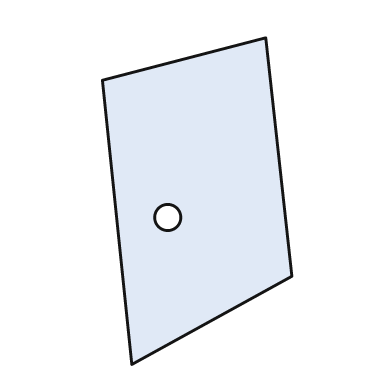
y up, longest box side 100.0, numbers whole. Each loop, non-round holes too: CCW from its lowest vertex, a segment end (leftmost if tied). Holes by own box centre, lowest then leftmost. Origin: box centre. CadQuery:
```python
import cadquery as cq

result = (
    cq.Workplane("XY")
    .moveTo(-20.0, -50.0)
    .lineTo(29.0, -23.0)
    .lineTo(21.0, 50.0)
    .lineTo(-29.0, 37.0)
    .close()
    .moveTo(-9.0, -5.0)
    .circle(4.0)
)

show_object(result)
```